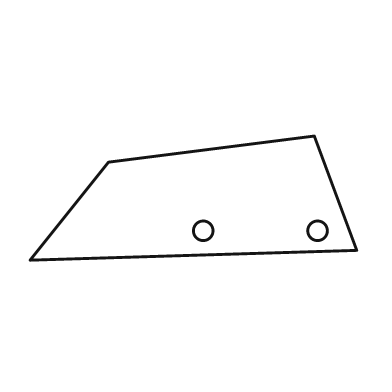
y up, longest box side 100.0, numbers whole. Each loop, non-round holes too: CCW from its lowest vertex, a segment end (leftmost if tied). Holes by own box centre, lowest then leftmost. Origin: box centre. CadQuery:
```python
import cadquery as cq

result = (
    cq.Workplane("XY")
    .moveTo(-50.0, -19.0)
    .lineTo(50.0, -16.0)
    .lineTo(37.0, 19.0)
    .lineTo(-26.0, 11.0)
    .close()
    .moveTo(3.0, -10.0)
    .circle(3.0)
    .moveTo(38.0, -10.0)
    .circle(3.0)
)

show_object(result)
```